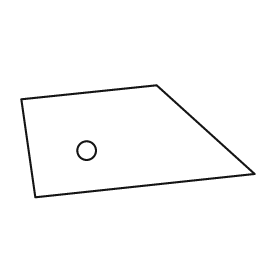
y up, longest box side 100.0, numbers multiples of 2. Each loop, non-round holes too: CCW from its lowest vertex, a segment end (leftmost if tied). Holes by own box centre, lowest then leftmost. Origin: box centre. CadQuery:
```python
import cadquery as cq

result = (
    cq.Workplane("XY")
    .moveTo(-44.0, -24.0)
    .lineTo(50.0, -14.0)
    .lineTo(8.0, 24.0)
    .lineTo(-50.0, 18.0)
    .close()
    .moveTo(-22.0, -4.0)
    .circle(4.0)
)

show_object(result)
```